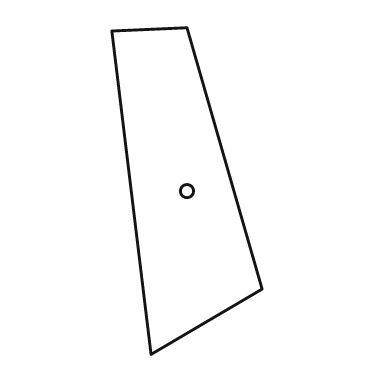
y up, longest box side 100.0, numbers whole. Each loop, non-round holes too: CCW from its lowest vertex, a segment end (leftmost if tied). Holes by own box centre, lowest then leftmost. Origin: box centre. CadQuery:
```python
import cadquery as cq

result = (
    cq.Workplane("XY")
    .moveTo(-11.0, -50.0)
    .lineTo(23.0, -30.0)
    .lineTo(0.0, 50.0)
    .lineTo(-23.0, 49.0)
    .close()
    .moveTo(0.0, 0.0)
    .circle(2.0)
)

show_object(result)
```